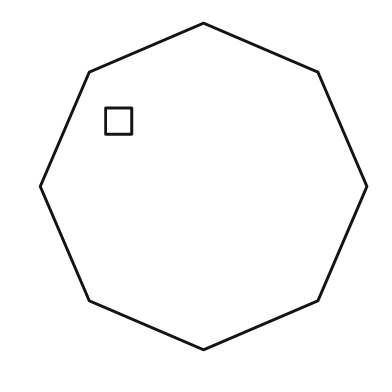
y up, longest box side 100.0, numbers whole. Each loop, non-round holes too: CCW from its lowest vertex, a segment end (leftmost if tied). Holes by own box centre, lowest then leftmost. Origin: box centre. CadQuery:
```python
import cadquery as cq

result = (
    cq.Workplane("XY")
    .moveTo(0.0, -50.0)
    .lineTo(35.0, -35.0)
    .lineTo(50.0, 0.0)
    .lineTo(35.0, 35.0)
    .lineTo(0.0, 50.0)
    .lineTo(-35.0, 35.0)
    .lineTo(-50.0, 0.0)
    .lineTo(-35.0, -35.0)
    .close()
    .moveTo(-30.0, 16.0)
    .lineTo(-22.0, 16.0)
    .lineTo(-22.0, 24.0)
    .lineTo(-30.0, 24.0)
    .close()
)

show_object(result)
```